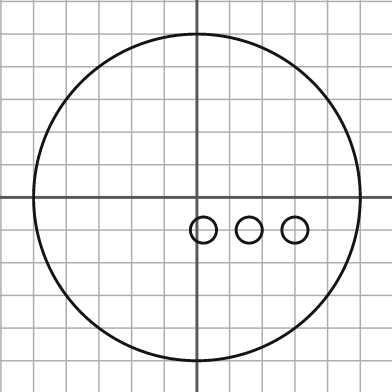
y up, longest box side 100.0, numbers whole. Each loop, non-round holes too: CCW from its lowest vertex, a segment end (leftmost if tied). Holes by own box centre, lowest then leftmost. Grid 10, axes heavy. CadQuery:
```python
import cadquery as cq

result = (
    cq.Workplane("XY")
    .moveTo(0.0, 0.0)
    .circle(50.0)
    .moveTo(2.0, -10.0)
    .circle(4.0)
    .moveTo(16.0, -10.0)
    .circle(4.0)
    .moveTo(30.0, -10.0)
    .circle(4.0)
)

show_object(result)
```